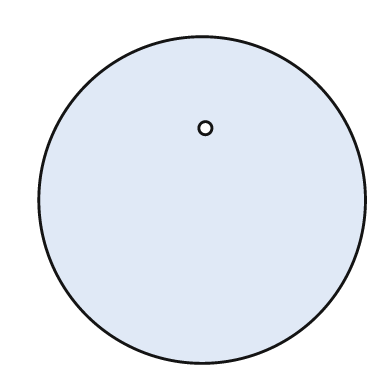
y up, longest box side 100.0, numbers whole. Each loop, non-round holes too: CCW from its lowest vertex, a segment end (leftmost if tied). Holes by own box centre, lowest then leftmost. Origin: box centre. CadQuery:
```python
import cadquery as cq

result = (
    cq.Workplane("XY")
    .moveTo(0.0, 0.0)
    .circle(50.0)
    .moveTo(1.0, 22.0)
    .circle(2.0)
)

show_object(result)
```